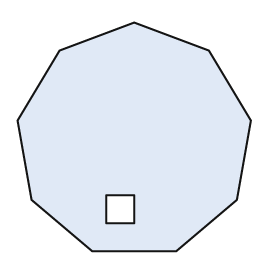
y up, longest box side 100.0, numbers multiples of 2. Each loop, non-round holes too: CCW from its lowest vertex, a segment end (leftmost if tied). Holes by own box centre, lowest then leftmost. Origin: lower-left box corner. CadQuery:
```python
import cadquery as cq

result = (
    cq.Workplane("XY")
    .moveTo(32.0, 0.0)
    .lineTo(68.0, 0.0)
    .lineTo(94.0, 22.0)
    .lineTo(100.0, 56.0)
    .lineTo(82.0, 86.0)
    .lineTo(50.0, 98.0)
    .lineTo(18.0, 86.0)
    .lineTo(0.0, 56.0)
    .lineTo(6.0, 22.0)
    .close()
    .moveTo(38.0, 12.0)
    .lineTo(50.0, 12.0)
    .lineTo(50.0, 24.0)
    .lineTo(38.0, 24.0)
    .close()
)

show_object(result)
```